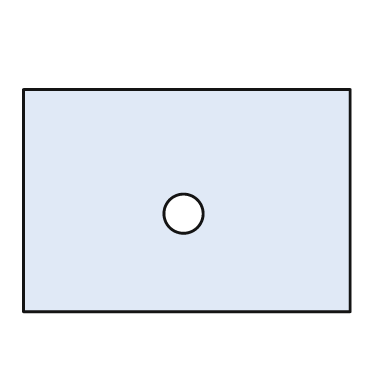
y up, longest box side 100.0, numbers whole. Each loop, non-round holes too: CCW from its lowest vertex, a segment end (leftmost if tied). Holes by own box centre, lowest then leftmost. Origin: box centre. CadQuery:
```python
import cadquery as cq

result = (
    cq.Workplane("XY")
    .moveTo(-50.0, -34.0)
    .lineTo(50.0, -34.0)
    .lineTo(50.0, 34.0)
    .lineTo(-50.0, 34.0)
    .close()
    .moveTo(-1.0, -4.0)
    .circle(6.0)
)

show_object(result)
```